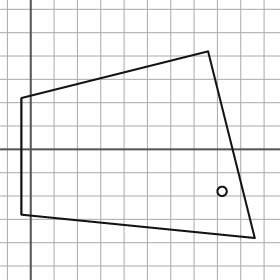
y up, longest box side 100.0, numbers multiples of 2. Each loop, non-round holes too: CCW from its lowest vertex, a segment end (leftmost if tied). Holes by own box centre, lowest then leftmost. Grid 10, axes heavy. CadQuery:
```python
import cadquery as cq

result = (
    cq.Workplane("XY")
    .moveTo(96.0, -38.0)
    .lineTo(76.0, 42.0)
    .lineTo(-4.0, 22.0)
    .lineTo(-4.0, -28.0)
    .close()
    .moveTo(82.0, -18.0)
    .circle(2.0)
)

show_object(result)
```